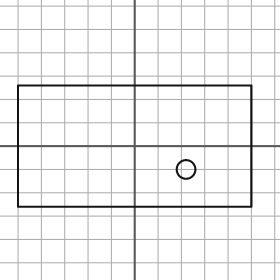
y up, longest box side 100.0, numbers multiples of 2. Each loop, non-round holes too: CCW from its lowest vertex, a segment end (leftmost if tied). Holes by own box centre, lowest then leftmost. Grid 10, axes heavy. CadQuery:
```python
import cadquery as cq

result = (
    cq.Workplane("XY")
    .moveTo(-50.0, -26.0)
    .lineTo(50.0, -26.0)
    .lineTo(50.0, 26.0)
    .lineTo(-50.0, 26.0)
    .close()
    .moveTo(22.0, -10.0)
    .circle(4.0)
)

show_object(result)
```